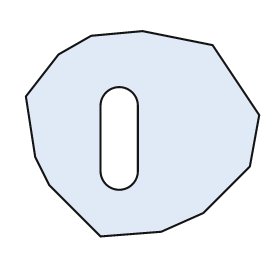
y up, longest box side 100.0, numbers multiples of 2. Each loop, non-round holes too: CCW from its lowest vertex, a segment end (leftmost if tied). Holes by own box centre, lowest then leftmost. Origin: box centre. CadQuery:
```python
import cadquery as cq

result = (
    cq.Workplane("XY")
    .moveTo(-18.0, -44.0)
    .lineTo(8.0, -42.0)
    .lineTo(26.0, -34.0)
    .lineTo(46.0, -14.0)
    .lineTo(50.0, 8.0)
    .lineTo(30.0, 38.0)
    .lineTo(0.0, 44.0)
    .lineTo(-22.0, 42.0)
    .lineTo(-36.0, 34.0)
    .lineTo(-50.0, 16.0)
    .lineTo(-46.0, -10.0)
    .lineTo(-40.0, -22.0)
    .close()
    .moveTo(-18.0, -16.0)
    .threePointArc((-10.0, -24.0), (-2.0, -16.0))
    .lineTo(-2.0, 12.0)
    .threePointArc((-10.0, 20.0), (-18.0, 12.0))
    .close()
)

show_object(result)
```